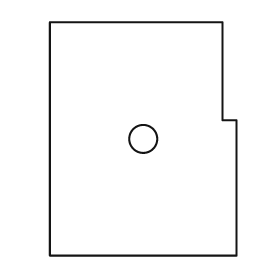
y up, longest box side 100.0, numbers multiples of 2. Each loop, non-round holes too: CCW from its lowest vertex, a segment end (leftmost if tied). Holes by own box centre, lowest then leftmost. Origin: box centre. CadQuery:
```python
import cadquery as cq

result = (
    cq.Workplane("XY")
    .moveTo(-40.0, -50.0)
    .lineTo(40.0, -50.0)
    .lineTo(40.0, 8.0)
    .lineTo(34.0, 8.0)
    .lineTo(34.0, 50.0)
    .lineTo(-40.0, 50.0)
    .close()
    .moveTo(0.0, 0.0)
    .circle(6.0)
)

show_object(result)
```